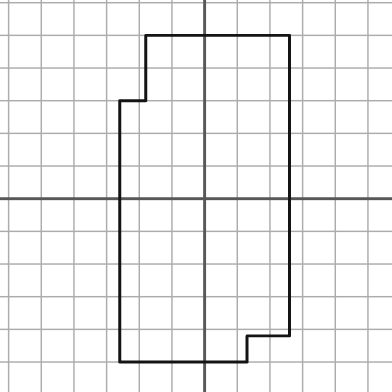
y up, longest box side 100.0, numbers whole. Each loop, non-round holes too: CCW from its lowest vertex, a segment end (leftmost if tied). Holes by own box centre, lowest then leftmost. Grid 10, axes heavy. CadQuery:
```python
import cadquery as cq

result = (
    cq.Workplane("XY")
    .moveTo(-26.0, -50.0)
    .lineTo(13.0, -50.0)
    .lineTo(13.0, -42.0)
    .lineTo(26.0, -42.0)
    .lineTo(26.0, 50.0)
    .lineTo(-18.0, 50.0)
    .lineTo(-18.0, 30.0)
    .lineTo(-26.0, 30.0)
    .close()
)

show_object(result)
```